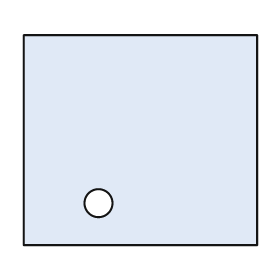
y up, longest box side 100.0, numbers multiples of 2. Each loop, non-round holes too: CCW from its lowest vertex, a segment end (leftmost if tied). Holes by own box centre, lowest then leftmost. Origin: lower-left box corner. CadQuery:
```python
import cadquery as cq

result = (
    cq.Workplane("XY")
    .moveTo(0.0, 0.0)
    .lineTo(100.0, 0.0)
    .lineTo(100.0, 90.0)
    .lineTo(0.0, 90.0)
    .close()
    .moveTo(32.0, 18.0)
    .circle(6.0)
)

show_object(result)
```